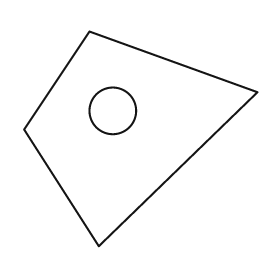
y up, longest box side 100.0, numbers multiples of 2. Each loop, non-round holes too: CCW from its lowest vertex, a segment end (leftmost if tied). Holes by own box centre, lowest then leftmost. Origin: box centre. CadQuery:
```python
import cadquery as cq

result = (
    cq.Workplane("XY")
    .moveTo(-18.0, -46.0)
    .lineTo(50.0, 20.0)
    .lineTo(-22.0, 46.0)
    .lineTo(-50.0, 4.0)
    .close()
    .moveTo(-12.0, 12.0)
    .circle(10.0)
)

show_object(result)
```